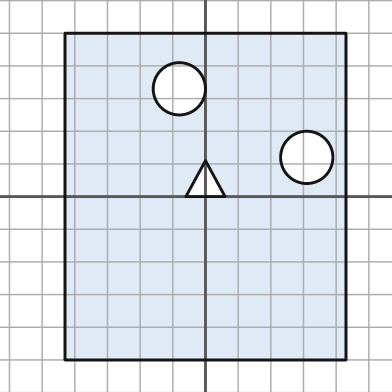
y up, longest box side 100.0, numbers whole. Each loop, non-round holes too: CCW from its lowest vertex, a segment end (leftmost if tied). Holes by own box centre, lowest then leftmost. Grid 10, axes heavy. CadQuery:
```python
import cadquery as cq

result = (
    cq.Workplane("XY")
    .moveTo(-43.0, -50.0)
    .lineTo(43.0, -50.0)
    .lineTo(43.0, 50.0)
    .lineTo(-43.0, 50.0)
    .close()
    .moveTo(-6.0, 0.0)
    .lineTo(6.0, 0.0)
    .lineTo(0.0, 11.0)
    .close()
    .moveTo(31.0, 12.0)
    .circle(8.0)
    .moveTo(-8.0, 33.0)
    .circle(8.0)
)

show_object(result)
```